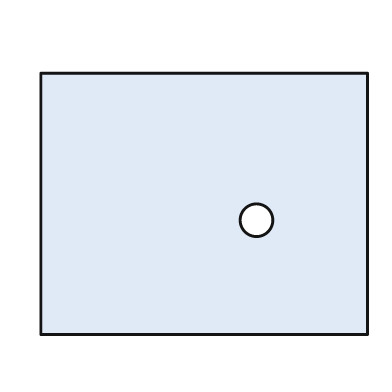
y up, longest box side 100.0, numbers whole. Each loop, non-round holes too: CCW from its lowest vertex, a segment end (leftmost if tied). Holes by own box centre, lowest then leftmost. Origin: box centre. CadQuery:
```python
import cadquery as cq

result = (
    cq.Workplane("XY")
    .moveTo(-50.0, -40.0)
    .lineTo(50.0, -40.0)
    .lineTo(50.0, 40.0)
    .lineTo(-50.0, 40.0)
    .close()
    .moveTo(16.0, -5.0)
    .circle(5.0)
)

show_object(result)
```